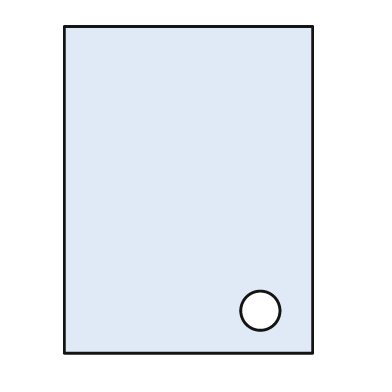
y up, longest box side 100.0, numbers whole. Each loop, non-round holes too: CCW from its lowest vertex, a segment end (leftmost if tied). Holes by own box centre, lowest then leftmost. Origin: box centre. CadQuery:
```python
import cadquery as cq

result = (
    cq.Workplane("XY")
    .moveTo(-38.0, -50.0)
    .lineTo(38.0, -50.0)
    .lineTo(38.0, 50.0)
    .lineTo(-38.0, 50.0)
    .close()
    .moveTo(22.0, -37.0)
    .circle(6.0)
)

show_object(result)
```